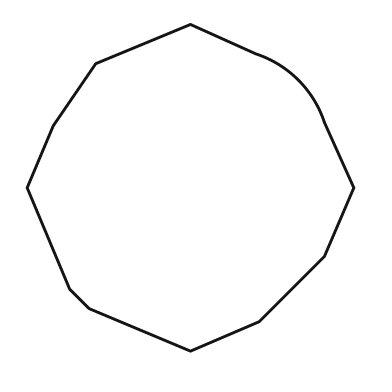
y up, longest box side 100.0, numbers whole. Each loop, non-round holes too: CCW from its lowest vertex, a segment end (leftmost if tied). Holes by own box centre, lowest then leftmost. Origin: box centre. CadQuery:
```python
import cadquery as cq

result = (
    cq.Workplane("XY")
    .moveTo(0.0, -50.0)
    .lineTo(21.0, -41.0)
    .lineTo(41.0, -21.0)
    .lineTo(50.0, 0.0)
    .lineTo(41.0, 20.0)
    .threePointArc((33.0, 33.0), (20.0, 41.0))
    .lineTo(0.0, 50.0)
    .lineTo(-29.0, 38.0)
    .lineTo(-42.0, 19.0)
    .lineTo(-50.0, 0.0)
    .lineTo(-37.0, -31.0)
    .lineTo(-31.0, -37.0)
    .close()
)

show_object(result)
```